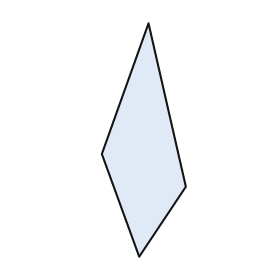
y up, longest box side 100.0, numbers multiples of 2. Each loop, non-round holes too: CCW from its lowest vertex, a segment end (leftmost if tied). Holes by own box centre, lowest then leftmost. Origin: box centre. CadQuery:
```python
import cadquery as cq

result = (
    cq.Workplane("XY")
    .moveTo(-2.0, -50.0)
    .lineTo(18.0, -20.0)
    .lineTo(2.0, 50.0)
    .lineTo(-18.0, -6.0)
    .close()
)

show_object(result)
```